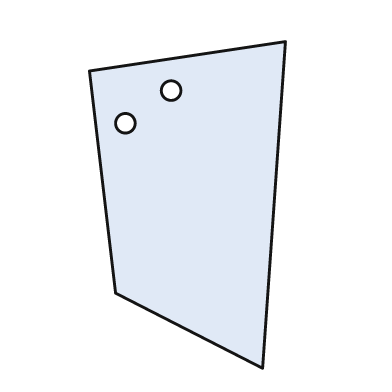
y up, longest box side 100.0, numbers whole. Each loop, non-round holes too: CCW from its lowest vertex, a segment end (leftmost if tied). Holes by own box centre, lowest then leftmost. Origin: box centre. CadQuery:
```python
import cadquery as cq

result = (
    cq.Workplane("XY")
    .moveTo(23.0, -50.0)
    .lineTo(30.0, 50.0)
    .lineTo(-30.0, 41.0)
    .lineTo(-22.0, -27.0)
    .close()
    .moveTo(-19.0, 25.0)
    .circle(3.0)
    .moveTo(-5.0, 35.0)
    .circle(3.0)
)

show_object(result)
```